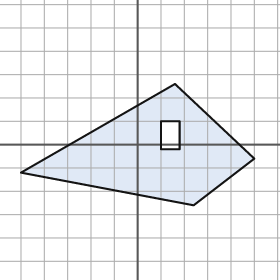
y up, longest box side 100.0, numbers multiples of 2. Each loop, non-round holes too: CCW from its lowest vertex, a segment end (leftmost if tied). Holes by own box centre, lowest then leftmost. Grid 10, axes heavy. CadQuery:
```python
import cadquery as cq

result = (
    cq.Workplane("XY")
    .moveTo(24.0, -26.0)
    .lineTo(50.0, -6.0)
    .lineTo(16.0, 26.0)
    .lineTo(-50.0, -12.0)
    .close()
    .moveTo(10.0, -2.0)
    .lineTo(18.0, -2.0)
    .lineTo(18.0, 10.0)
    .lineTo(10.0, 10.0)
    .close()
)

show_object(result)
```